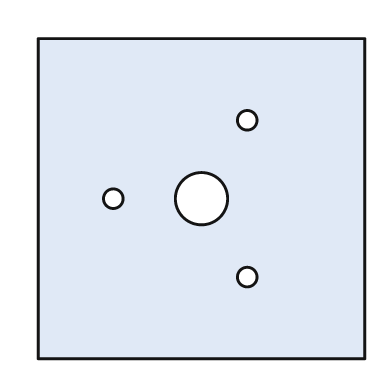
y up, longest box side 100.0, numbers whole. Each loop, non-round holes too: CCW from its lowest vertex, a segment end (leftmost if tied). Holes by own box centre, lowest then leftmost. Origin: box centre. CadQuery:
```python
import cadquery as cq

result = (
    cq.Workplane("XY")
    .moveTo(-50.0, -49.0)
    .lineTo(50.0, -49.0)
    .lineTo(50.0, 49.0)
    .lineTo(-50.0, 49.0)
    .close()
    .moveTo(14.0, -24.0)
    .circle(3.0)
    .moveTo(-27.0, 0.0)
    .circle(3.0)
    .moveTo(0.0, 0.0)
    .circle(8.0)
    .moveTo(14.0, 24.0)
    .circle(3.0)
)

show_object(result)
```